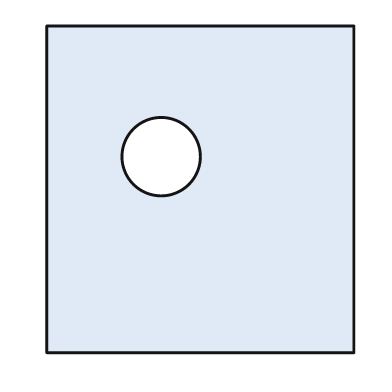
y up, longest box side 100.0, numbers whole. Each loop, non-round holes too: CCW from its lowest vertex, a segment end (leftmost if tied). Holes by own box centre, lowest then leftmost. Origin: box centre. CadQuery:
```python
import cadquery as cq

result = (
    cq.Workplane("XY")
    .moveTo(-47.0, -50.0)
    .lineTo(47.0, -50.0)
    .lineTo(47.0, 50.0)
    .lineTo(-47.0, 50.0)
    .close()
    .moveTo(-12.0, 10.0)
    .circle(12.0)
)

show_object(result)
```